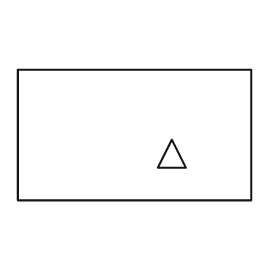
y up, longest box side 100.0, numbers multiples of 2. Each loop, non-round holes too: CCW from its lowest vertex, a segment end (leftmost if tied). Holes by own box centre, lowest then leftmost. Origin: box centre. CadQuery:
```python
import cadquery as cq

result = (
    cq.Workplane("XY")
    .moveTo(-50.0, -28.0)
    .lineTo(50.0, -28.0)
    .lineTo(50.0, 28.0)
    .lineTo(-50.0, 28.0)
    .close()
    .moveTo(10.0, -14.0)
    .lineTo(22.0, -14.0)
    .lineTo(16.0, -2.0)
    .close()
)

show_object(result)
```